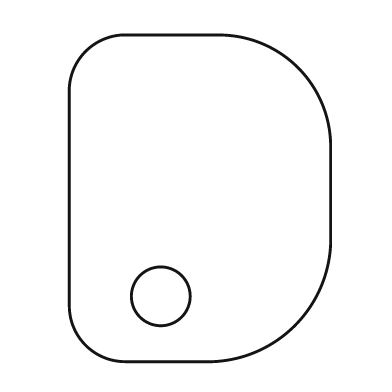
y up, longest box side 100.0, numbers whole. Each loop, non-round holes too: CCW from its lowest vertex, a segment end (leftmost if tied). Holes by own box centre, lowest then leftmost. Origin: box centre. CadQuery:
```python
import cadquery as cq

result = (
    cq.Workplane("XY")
    .moveTo(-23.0, -50.0)
    .lineTo(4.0, -50.0)
    .threePointArc((29.0, -39.0), (40.0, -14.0))
    .lineTo(40.0, 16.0)
    .threePointArc((30.0, 40.0), (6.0, 50.0))
    .lineTo(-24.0, 50.0)
    .threePointArc((-35.0, 45.0), (-40.0, 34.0))
    .lineTo(-40.0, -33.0)
    .threePointArc((-35.0, -45.0), (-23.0, -50.0))
    .close()
    .moveTo(-12.0, -30.0)
    .circle(9.0)
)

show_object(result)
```